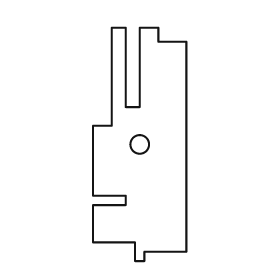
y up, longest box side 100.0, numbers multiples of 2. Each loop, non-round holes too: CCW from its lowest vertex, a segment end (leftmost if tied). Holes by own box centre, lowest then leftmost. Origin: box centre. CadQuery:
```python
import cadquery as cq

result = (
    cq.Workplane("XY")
    .moveTo(-2.0, -50.0)
    .lineTo(2.0, -50.0)
    .lineTo(2.0, -46.0)
    .lineTo(20.0, -46.0)
    .lineTo(20.0, 44.0)
    .lineTo(8.0, 44.0)
    .lineTo(8.0, 50.0)
    .lineTo(0.0, 50.0)
    .lineTo(0.0, 16.0)
    .lineTo(-6.0, 16.0)
    .lineTo(-6.0, 50.0)
    .lineTo(-12.0, 50.0)
    .lineTo(-12.0, 8.0)
    .lineTo(-20.0, 8.0)
    .lineTo(-20.0, -22.0)
    .lineTo(-6.0, -22.0)
    .lineTo(-6.0, -26.0)
    .lineTo(-20.0, -26.0)
    .lineTo(-20.0, -42.0)
    .lineTo(-2.0, -42.0)
    .close()
    .moveTo(0.0, 0.0)
    .circle(4.0)
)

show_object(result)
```